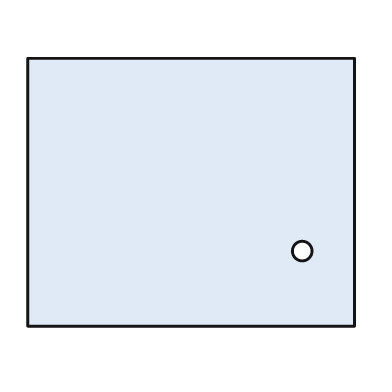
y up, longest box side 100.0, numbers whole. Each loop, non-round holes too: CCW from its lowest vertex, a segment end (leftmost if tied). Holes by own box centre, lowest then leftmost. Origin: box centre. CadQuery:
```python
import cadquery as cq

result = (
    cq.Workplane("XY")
    .moveTo(-50.0, -41.0)
    .lineTo(50.0, -41.0)
    .lineTo(50.0, 41.0)
    .lineTo(-50.0, 41.0)
    .close()
    .moveTo(34.0, -18.0)
    .circle(3.0)
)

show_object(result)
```